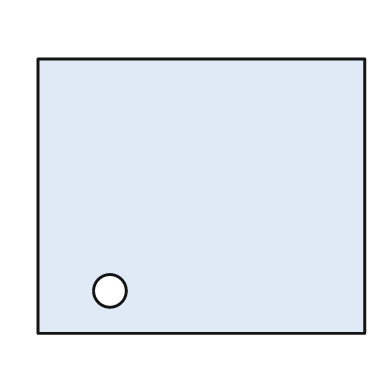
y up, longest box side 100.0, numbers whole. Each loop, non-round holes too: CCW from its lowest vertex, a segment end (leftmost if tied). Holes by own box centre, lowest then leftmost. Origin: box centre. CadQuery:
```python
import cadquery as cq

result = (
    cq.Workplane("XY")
    .moveTo(-50.0, -42.0)
    .lineTo(50.0, -42.0)
    .lineTo(50.0, 42.0)
    .lineTo(-50.0, 42.0)
    .close()
    .moveTo(-28.0, -29.0)
    .circle(5.0)
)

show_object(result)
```